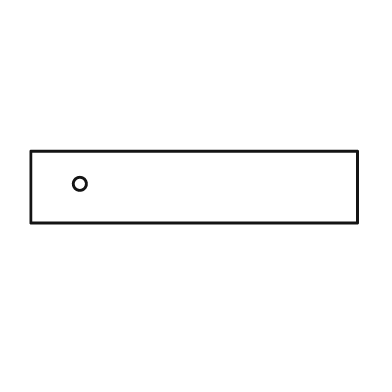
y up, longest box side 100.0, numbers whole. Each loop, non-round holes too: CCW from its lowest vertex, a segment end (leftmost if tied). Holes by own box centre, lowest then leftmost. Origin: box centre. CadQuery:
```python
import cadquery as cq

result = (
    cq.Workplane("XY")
    .moveTo(-50.0, -11.0)
    .lineTo(50.0, -11.0)
    .lineTo(50.0, 11.0)
    .lineTo(-50.0, 11.0)
    .close()
    .moveTo(-35.0, 1.0)
    .circle(2.0)
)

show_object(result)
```